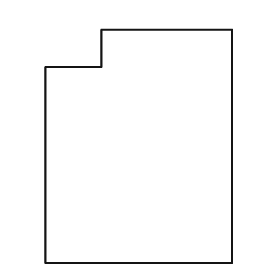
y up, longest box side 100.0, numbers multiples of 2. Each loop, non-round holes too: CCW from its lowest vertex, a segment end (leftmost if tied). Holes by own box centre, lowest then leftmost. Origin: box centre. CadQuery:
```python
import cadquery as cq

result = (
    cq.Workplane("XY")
    .moveTo(-40.0, -50.0)
    .lineTo(40.0, -50.0)
    .lineTo(40.0, 50.0)
    .lineTo(-16.0, 50.0)
    .lineTo(-16.0, 34.0)
    .lineTo(-40.0, 34.0)
    .close()
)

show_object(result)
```